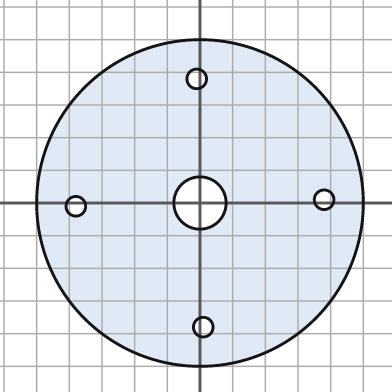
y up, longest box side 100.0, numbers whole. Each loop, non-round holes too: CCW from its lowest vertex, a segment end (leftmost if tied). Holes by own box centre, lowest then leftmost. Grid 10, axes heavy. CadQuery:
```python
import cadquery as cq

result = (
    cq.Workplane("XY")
    .moveTo(0.0, 0.0)
    .circle(50.0)
    .moveTo(1.0, -38.0)
    .circle(3.0)
    .moveTo(-38.0, -1.0)
    .circle(3.0)
    .moveTo(0.0, 0.0)
    .circle(8.0)
    .moveTo(38.0, 1.0)
    .circle(3.0)
    .moveTo(-1.0, 38.0)
    .circle(3.0)
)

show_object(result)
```